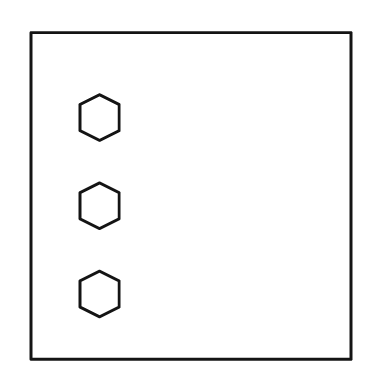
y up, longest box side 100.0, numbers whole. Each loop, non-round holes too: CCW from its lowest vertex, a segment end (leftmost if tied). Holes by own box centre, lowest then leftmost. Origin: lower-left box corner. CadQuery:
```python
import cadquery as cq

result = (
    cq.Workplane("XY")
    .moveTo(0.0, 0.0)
    .lineTo(98.0, 0.0)
    .lineTo(98.0, 100.0)
    .lineTo(0.0, 100.0)
    .close()
    .moveTo(21.0, 13.0)
    .lineTo(27.0, 16.0)
    .lineTo(27.0, 24.0)
    .lineTo(21.0, 27.0)
    .lineTo(15.0, 24.0)
    .lineTo(15.0, 16.0)
    .close()
    .moveTo(21.0, 40.0)
    .lineTo(27.0, 43.0)
    .lineTo(27.0, 51.0)
    .lineTo(21.0, 54.0)
    .lineTo(15.0, 51.0)
    .lineTo(15.0, 43.0)
    .close()
    .moveTo(21.0, 67.0)
    .lineTo(27.0, 70.0)
    .lineTo(27.0, 78.0)
    .lineTo(21.0, 81.0)
    .lineTo(15.0, 78.0)
    .lineTo(15.0, 70.0)
    .close()
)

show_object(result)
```